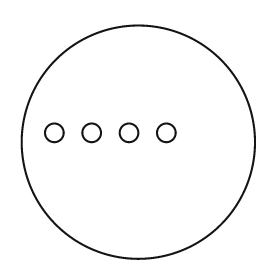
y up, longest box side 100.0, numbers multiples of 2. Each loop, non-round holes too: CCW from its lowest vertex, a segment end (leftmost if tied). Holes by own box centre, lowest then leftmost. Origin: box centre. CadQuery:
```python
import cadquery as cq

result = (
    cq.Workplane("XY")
    .moveTo(0.0, 0.0)
    .circle(50.0)
    .moveTo(-36.0, 4.0)
    .circle(4.0)
    .moveTo(-20.0, 4.0)
    .circle(4.0)
    .moveTo(-4.0, 4.0)
    .circle(4.0)
    .moveTo(12.0, 4.0)
    .circle(4.0)
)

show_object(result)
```